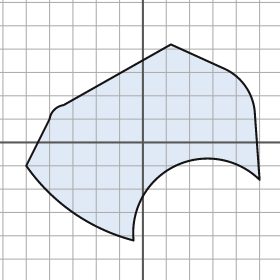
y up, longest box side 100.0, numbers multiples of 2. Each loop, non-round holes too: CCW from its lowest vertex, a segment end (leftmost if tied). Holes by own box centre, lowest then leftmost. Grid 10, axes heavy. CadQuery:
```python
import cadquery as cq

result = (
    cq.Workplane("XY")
    .moveTo(-4.0, -42.0)
    .threePointArc((14.0, -10.0), (50.0, -16.0))
    .lineTo(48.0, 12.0)
    .threePointArc((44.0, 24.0), (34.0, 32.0))
    .lineTo(12.0, 42.0)
    .lineTo(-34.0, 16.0)
    .threePointArc((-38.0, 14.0), (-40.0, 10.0))
    .lineTo(-50.0, -10.0)
    .threePointArc((-30.0, -30.0), (-4.0, -42.0))
    .close()
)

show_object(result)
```